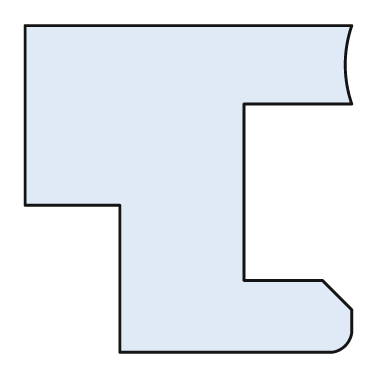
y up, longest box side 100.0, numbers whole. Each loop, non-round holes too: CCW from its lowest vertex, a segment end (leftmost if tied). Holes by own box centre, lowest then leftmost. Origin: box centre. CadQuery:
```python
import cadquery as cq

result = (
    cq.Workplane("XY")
    .moveTo(-21.0, -50.0)
    .lineTo(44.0, -50.0)
    .threePointArc((48.0, -48.0), (50.0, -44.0))
    .lineTo(50.0, -37.0)
    .lineTo(41.0, -28.0)
    .lineTo(17.0, -28.0)
    .lineTo(17.0, 26.0)
    .lineTo(50.0, 26.0)
    .threePointArc((48.0, 38.0), (50.0, 50.0))
    .lineTo(-50.0, 50.0)
    .lineTo(-50.0, -5.0)
    .lineTo(-21.0, -5.0)
    .close()
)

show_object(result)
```